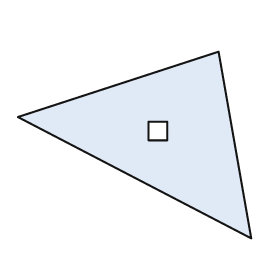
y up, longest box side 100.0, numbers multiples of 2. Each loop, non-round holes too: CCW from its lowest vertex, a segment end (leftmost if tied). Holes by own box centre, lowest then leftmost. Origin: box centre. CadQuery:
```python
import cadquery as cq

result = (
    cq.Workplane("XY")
    .moveTo(50.0, -40.0)
    .lineTo(36.0, 40.0)
    .lineTo(-50.0, 12.0)
    .close()
    .moveTo(6.0, 2.0)
    .lineTo(14.0, 2.0)
    .lineTo(14.0, 10.0)
    .lineTo(6.0, 10.0)
    .close()
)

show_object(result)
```